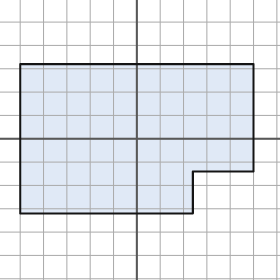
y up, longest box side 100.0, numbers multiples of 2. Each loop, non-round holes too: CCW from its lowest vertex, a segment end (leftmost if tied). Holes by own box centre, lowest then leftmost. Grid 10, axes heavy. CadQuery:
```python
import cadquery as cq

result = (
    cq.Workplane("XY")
    .moveTo(-50.0, -32.0)
    .lineTo(24.0, -32.0)
    .lineTo(24.0, -14.0)
    .lineTo(50.0, -14.0)
    .lineTo(50.0, 32.0)
    .lineTo(-50.0, 32.0)
    .close()
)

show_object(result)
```